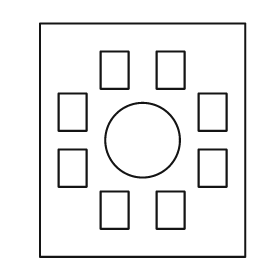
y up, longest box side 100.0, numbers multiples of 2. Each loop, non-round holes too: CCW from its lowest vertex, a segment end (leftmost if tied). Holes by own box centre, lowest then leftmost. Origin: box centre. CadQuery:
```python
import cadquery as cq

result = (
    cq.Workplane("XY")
    .moveTo(-44.0, -50.0)
    .lineTo(44.0, -50.0)
    .lineTo(44.0, 50.0)
    .lineTo(-44.0, 50.0)
    .close()
    .moveTo(-18.0, -38.0)
    .lineTo(-6.0, -38.0)
    .lineTo(-6.0, -22.0)
    .lineTo(-18.0, -22.0)
    .close()
    .moveTo(6.0, -38.0)
    .lineTo(18.0, -38.0)
    .lineTo(18.0, -22.0)
    .lineTo(6.0, -22.0)
    .close()
    .moveTo(-36.0, -20.0)
    .lineTo(-24.0, -20.0)
    .lineTo(-24.0, -4.0)
    .lineTo(-36.0, -4.0)
    .close()
    .moveTo(24.0, -20.0)
    .lineTo(36.0, -20.0)
    .lineTo(36.0, -4.0)
    .lineTo(24.0, -4.0)
    .close()
    .moveTo(0.0, 0.0)
    .circle(16.0)
    .moveTo(-36.0, 4.0)
    .lineTo(-24.0, 4.0)
    .lineTo(-24.0, 20.0)
    .lineTo(-36.0, 20.0)
    .close()
    .moveTo(24.0, 4.0)
    .lineTo(36.0, 4.0)
    .lineTo(36.0, 20.0)
    .lineTo(24.0, 20.0)
    .close()
    .moveTo(-18.0, 22.0)
    .lineTo(-6.0, 22.0)
    .lineTo(-6.0, 38.0)
    .lineTo(-18.0, 38.0)
    .close()
    .moveTo(6.0, 22.0)
    .lineTo(18.0, 22.0)
    .lineTo(18.0, 38.0)
    .lineTo(6.0, 38.0)
    .close()
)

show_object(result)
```